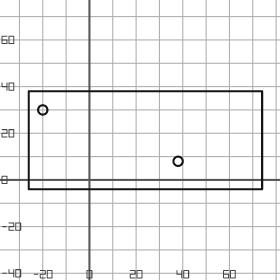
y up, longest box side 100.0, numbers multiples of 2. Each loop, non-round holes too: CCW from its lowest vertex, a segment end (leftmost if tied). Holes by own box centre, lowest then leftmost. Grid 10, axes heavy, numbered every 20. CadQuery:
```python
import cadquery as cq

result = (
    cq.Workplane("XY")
    .moveTo(-26.0, -4.0)
    .lineTo(74.0, -4.0)
    .lineTo(74.0, 38.0)
    .lineTo(-26.0, 38.0)
    .close()
    .moveTo(38.0, 8.0)
    .circle(2.0)
    .moveTo(-20.0, 30.0)
    .circle(2.0)
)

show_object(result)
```